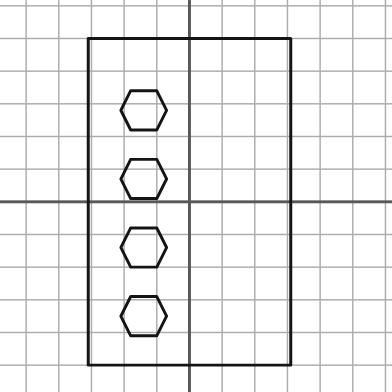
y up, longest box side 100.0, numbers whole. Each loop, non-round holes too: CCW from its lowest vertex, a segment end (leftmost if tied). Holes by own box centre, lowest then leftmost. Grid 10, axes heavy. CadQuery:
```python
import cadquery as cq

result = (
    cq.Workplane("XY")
    .moveTo(-31.0, -50.0)
    .lineTo(31.0, -50.0)
    .lineTo(31.0, 50.0)
    .lineTo(-31.0, 50.0)
    .close()
    .moveTo(-18.0, -41.0)
    .lineTo(-10.0, -41.0)
    .lineTo(-7.0, -35.0)
    .lineTo(-10.0, -29.0)
    .lineTo(-18.0, -29.0)
    .lineTo(-21.0, -35.0)
    .close()
    .moveTo(-18.0, -20.0)
    .lineTo(-10.0, -20.0)
    .lineTo(-7.0, -14.0)
    .lineTo(-10.0, -8.0)
    .lineTo(-18.0, -8.0)
    .lineTo(-21.0, -14.0)
    .close()
    .moveTo(-18.0, 1.0)
    .lineTo(-10.0, 1.0)
    .lineTo(-7.0, 7.0)
    .lineTo(-10.0, 13.0)
    .lineTo(-18.0, 13.0)
    .lineTo(-21.0, 7.0)
    .close()
    .moveTo(-18.0, 22.0)
    .lineTo(-10.0, 22.0)
    .lineTo(-7.0, 28.0)
    .lineTo(-10.0, 34.0)
    .lineTo(-18.0, 34.0)
    .lineTo(-21.0, 28.0)
    .close()
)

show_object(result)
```